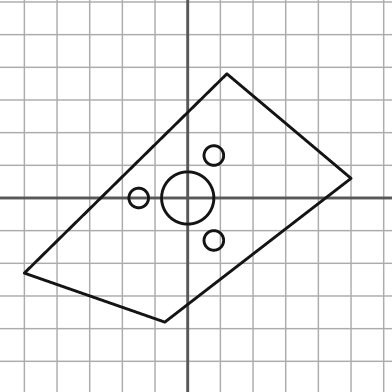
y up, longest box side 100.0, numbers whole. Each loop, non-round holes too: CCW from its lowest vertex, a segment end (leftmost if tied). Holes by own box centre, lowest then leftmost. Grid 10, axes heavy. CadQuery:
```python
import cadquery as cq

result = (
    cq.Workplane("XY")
    .moveTo(-7.0, -38.0)
    .lineTo(50.0, 6.0)
    .lineTo(12.0, 38.0)
    .lineTo(-50.0, -23.0)
    .close()
    .moveTo(8.0, -13.0)
    .circle(3.0)
    .moveTo(-15.0, 0.0)
    .circle(3.0)
    .moveTo(0.0, 0.0)
    .circle(8.0)
    .moveTo(8.0, 13.0)
    .circle(3.0)
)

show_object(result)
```